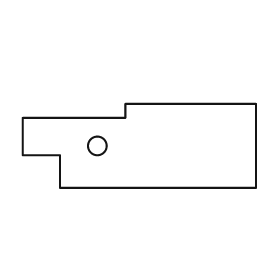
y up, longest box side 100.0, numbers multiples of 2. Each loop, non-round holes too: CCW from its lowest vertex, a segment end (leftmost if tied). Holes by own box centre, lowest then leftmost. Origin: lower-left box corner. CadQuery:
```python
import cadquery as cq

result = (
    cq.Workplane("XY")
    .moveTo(16.0, 0.0)
    .lineTo(100.0, 0.0)
    .lineTo(100.0, 36.0)
    .lineTo(44.0, 36.0)
    .lineTo(44.0, 30.0)
    .lineTo(0.0, 30.0)
    .lineTo(0.0, 14.0)
    .lineTo(16.0, 14.0)
    .close()
    .moveTo(32.0, 18.0)
    .circle(4.0)
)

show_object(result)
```